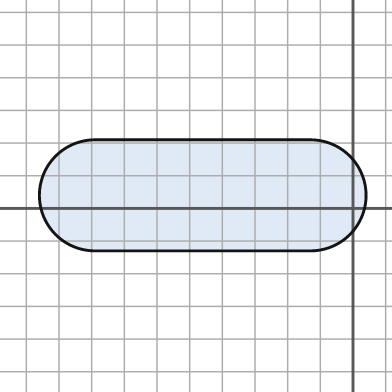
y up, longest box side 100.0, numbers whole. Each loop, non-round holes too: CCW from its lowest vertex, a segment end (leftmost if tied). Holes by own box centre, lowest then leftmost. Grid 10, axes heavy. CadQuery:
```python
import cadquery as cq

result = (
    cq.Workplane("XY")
    .moveTo(-79.0, -13.0)
    .lineTo(-13.0, -13.0)
    .threePointArc((4.0, 4.0), (-13.0, 21.0))
    .lineTo(-79.0, 21.0)
    .threePointArc((-96.0, 4.0), (-79.0, -13.0))
    .close()
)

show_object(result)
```